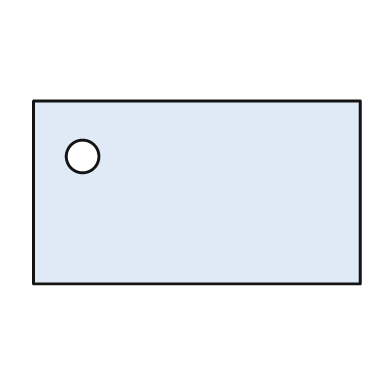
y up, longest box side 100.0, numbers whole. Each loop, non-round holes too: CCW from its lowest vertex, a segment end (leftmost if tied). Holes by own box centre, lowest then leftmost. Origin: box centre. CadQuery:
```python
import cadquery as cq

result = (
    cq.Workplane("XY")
    .moveTo(-50.0, -28.0)
    .lineTo(50.0, -28.0)
    .lineTo(50.0, 28.0)
    .lineTo(-50.0, 28.0)
    .close()
    .moveTo(-35.0, 11.0)
    .circle(5.0)
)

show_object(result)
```